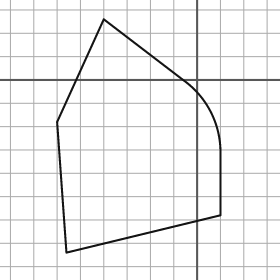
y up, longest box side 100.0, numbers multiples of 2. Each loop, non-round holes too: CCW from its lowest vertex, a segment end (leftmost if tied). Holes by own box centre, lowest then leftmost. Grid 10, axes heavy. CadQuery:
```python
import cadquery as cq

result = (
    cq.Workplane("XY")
    .moveTo(-56.0, -74.0)
    .lineTo(10.0, -58.0)
    .lineTo(10.0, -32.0)
    .threePointArc((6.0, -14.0), (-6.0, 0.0))
    .lineTo(-40.0, 26.0)
    .lineTo(-60.0, -18.0)
    .close()
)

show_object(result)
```